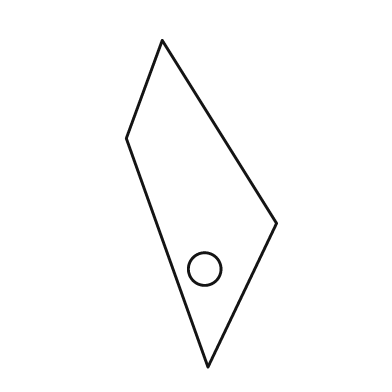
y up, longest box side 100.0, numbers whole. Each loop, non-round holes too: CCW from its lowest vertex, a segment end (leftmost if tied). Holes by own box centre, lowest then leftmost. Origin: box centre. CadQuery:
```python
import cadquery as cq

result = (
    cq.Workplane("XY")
    .moveTo(2.0, -50.0)
    .lineTo(23.0, -6.0)
    .lineTo(-12.0, 50.0)
    .lineTo(-23.0, 20.0)
    .close()
    .moveTo(1.0, -20.0)
    .circle(5.0)
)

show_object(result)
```